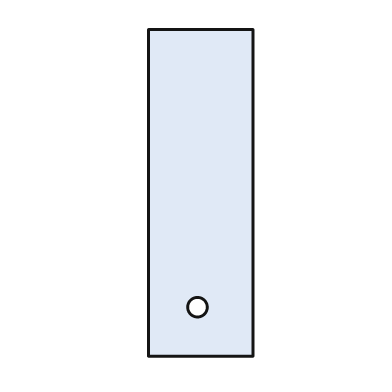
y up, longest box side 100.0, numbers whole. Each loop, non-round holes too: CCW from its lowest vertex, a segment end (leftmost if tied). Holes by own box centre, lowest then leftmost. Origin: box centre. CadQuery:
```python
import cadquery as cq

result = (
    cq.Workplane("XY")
    .moveTo(-16.0, -50.0)
    .lineTo(16.0, -50.0)
    .lineTo(16.0, 50.0)
    .lineTo(-16.0, 50.0)
    .close()
    .moveTo(-1.0, -35.0)
    .circle(3.0)
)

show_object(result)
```